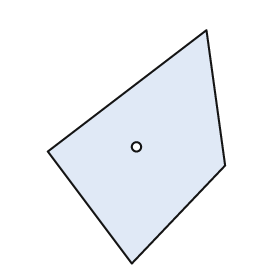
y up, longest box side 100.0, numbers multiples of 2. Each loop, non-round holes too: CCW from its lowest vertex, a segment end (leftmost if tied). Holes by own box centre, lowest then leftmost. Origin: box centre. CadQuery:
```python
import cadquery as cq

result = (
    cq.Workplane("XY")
    .moveTo(-2.0, -50.0)
    .lineTo(38.0, -8.0)
    .lineTo(30.0, 50.0)
    .lineTo(-38.0, -2.0)
    .close()
    .moveTo(0.0, 0.0)
    .circle(2.0)
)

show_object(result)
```